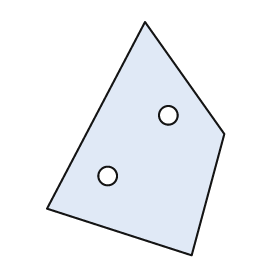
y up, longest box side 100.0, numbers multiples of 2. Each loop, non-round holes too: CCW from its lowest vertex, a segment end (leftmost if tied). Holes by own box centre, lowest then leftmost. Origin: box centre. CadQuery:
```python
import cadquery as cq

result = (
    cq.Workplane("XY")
    .moveTo(24.0, -50.0)
    .lineTo(38.0, 2.0)
    .lineTo(4.0, 50.0)
    .lineTo(-38.0, -30.0)
    .close()
    .moveTo(-12.0, -16.0)
    .circle(4.0)
    .moveTo(14.0, 10.0)
    .circle(4.0)
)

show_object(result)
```